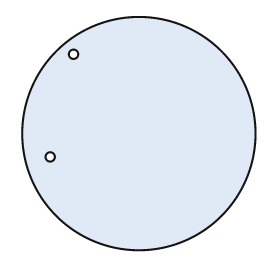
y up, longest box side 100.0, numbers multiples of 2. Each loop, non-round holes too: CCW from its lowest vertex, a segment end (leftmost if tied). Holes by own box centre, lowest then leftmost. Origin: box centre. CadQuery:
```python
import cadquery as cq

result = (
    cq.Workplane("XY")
    .moveTo(0.0, 0.0)
    .circle(50.0)
    .moveTo(-38.0, -10.0)
    .circle(2.0)
    .moveTo(-28.0, 34.0)
    .circle(2.0)
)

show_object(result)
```